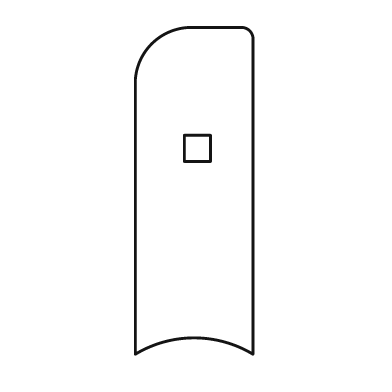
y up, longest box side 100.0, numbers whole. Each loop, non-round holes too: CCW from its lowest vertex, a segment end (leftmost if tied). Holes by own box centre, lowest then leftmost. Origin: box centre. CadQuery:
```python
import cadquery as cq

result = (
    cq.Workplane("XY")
    .moveTo(-18.0, -50.0)
    .threePointArc((0.0, -45.0), (18.0, -50.0))
    .lineTo(18.0, 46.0)
    .threePointArc((17.0, 49.0), (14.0, 50.0))
    .lineTo(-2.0, 50.0)
    .threePointArc((-13.0, 45.0), (-18.0, 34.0))
    .close()
    .moveTo(-3.0, 9.0)
    .lineTo(5.0, 9.0)
    .lineTo(5.0, 17.0)
    .lineTo(-3.0, 17.0)
    .close()
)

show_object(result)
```